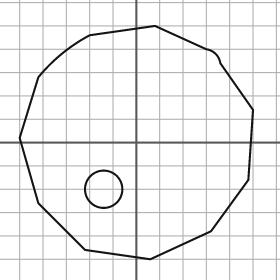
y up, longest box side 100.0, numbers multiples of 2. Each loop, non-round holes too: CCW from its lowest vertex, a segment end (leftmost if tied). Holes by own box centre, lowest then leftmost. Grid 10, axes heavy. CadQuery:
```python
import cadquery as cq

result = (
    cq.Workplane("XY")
    .moveTo(6.0, -50.0)
    .lineTo(32.0, -38.0)
    .lineTo(48.0, -16.0)
    .lineTo(50.0, 14.0)
    .lineTo(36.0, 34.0)
    .threePointArc((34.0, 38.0), (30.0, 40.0))
    .lineTo(8.0, 50.0)
    .lineTo(-20.0, 46.0)
    .threePointArc((-32.0, 38.0), (-42.0, 28.0))
    .lineTo(-50.0, 2.0)
    .lineTo(-42.0, -26.0)
    .lineTo(-22.0, -46.0)
    .close()
    .moveTo(-14.0, -20.0)
    .circle(8.0)
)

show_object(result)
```